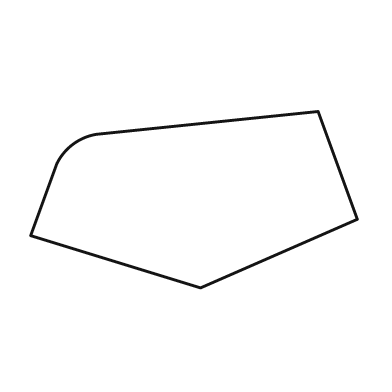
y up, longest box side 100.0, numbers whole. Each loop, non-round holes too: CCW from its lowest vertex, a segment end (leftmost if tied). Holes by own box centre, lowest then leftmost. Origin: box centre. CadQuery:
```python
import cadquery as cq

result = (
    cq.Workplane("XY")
    .moveTo(2.0, -27.0)
    .lineTo(50.0, -6.0)
    .lineTo(38.0, 27.0)
    .lineTo(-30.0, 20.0)
    .threePointArc((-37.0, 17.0), (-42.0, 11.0))
    .lineTo(-50.0, -11.0)
    .close()
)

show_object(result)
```